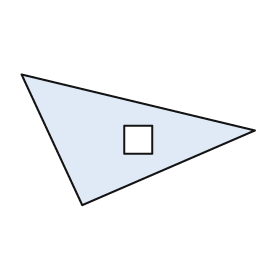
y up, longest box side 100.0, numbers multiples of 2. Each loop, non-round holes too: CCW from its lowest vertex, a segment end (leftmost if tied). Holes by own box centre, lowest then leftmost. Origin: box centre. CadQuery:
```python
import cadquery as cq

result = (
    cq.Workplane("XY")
    .moveTo(-24.0, -28.0)
    .lineTo(50.0, 4.0)
    .lineTo(-50.0, 28.0)
    .close()
    .moveTo(-6.0, -6.0)
    .lineTo(6.0, -6.0)
    .lineTo(6.0, 6.0)
    .lineTo(-6.0, 6.0)
    .close()
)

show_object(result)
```